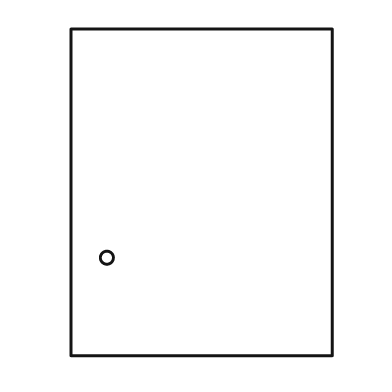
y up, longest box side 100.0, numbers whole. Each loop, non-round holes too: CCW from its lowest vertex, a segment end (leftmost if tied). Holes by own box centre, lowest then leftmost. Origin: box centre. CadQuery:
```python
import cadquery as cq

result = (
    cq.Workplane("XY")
    .moveTo(-40.0, -50.0)
    .lineTo(40.0, -50.0)
    .lineTo(40.0, 50.0)
    .lineTo(-40.0, 50.0)
    .close()
    .moveTo(-29.0, -20.0)
    .circle(2.0)
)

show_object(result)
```